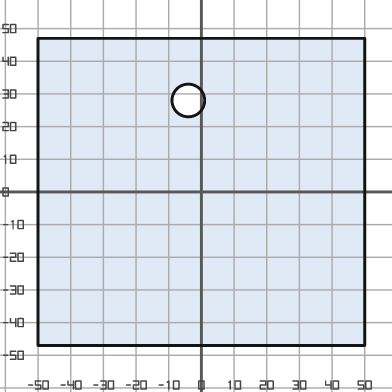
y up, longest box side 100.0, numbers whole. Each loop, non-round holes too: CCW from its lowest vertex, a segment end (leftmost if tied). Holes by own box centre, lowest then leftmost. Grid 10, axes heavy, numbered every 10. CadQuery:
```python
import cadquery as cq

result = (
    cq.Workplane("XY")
    .moveTo(-50.0, -47.0)
    .lineTo(50.0, -47.0)
    .lineTo(50.0, 47.0)
    .lineTo(-50.0, 47.0)
    .close()
    .moveTo(-4.0, 28.0)
    .circle(5.0)
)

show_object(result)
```